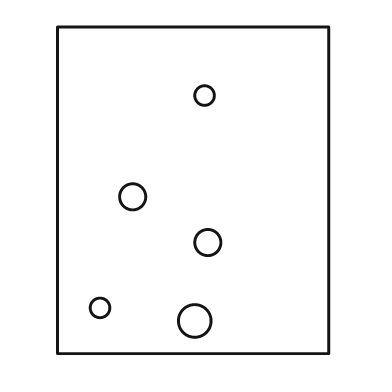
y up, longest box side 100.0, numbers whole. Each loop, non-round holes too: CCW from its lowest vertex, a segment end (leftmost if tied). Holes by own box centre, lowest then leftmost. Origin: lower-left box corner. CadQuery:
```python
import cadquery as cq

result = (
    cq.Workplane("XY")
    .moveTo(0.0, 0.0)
    .lineTo(83.0, 0.0)
    .lineTo(83.0, 100.0)
    .lineTo(0.0, 100.0)
    .close()
    .moveTo(42.0, 10.0)
    .circle(5.0)
    .moveTo(13.0, 14.0)
    .circle(3.0)
    .moveTo(46.0, 34.0)
    .circle(4.0)
    .moveTo(23.0, 48.0)
    .circle(4.0)
    .moveTo(45.0, 79.0)
    .circle(3.0)
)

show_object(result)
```